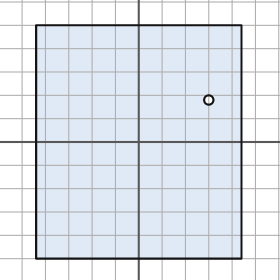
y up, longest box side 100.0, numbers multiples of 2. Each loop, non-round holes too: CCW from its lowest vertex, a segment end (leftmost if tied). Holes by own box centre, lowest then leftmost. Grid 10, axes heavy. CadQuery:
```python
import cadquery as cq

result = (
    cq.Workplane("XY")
    .moveTo(-44.0, -50.0)
    .lineTo(44.0, -50.0)
    .lineTo(44.0, 50.0)
    .lineTo(-44.0, 50.0)
    .close()
    .moveTo(30.0, 18.0)
    .circle(2.0)
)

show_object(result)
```